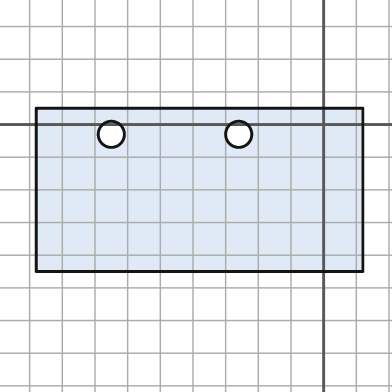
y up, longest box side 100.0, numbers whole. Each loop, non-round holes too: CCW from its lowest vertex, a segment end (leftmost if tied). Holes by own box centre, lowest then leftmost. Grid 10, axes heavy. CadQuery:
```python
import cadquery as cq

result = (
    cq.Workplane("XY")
    .moveTo(-88.0, -45.0)
    .lineTo(12.0, -45.0)
    .lineTo(12.0, 5.0)
    .lineTo(-88.0, 5.0)
    .close()
    .moveTo(-65.0, -3.0)
    .circle(4.0)
    .moveTo(-26.0, -3.0)
    .circle(4.0)
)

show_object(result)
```